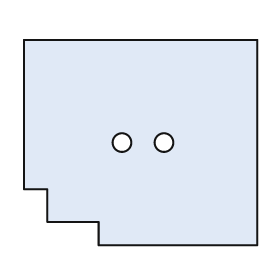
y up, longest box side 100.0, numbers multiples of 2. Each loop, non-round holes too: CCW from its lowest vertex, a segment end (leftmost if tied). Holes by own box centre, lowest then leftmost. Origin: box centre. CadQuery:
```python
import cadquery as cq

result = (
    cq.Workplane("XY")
    .moveTo(-18.0, -44.0)
    .lineTo(50.0, -44.0)
    .lineTo(50.0, 44.0)
    .lineTo(-50.0, 44.0)
    .lineTo(-50.0, -20.0)
    .lineTo(-40.0, -20.0)
    .lineTo(-40.0, -34.0)
    .lineTo(-18.0, -34.0)
    .close()
    .moveTo(-8.0, 0.0)
    .circle(4.0)
    .moveTo(10.0, 0.0)
    .circle(4.0)
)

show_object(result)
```